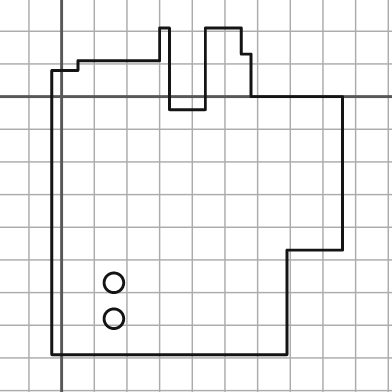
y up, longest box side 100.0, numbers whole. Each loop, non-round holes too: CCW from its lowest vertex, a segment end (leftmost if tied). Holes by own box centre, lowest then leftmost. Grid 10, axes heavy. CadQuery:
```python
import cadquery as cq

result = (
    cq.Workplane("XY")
    .moveTo(-3.0, -79.0)
    .lineTo(69.0, -79.0)
    .lineTo(69.0, -47.0)
    .lineTo(86.0, -47.0)
    .lineTo(86.0, 0.0)
    .lineTo(58.0, 0.0)
    .lineTo(58.0, 13.0)
    .lineTo(55.0, 13.0)
    .lineTo(55.0, 21.0)
    .lineTo(44.0, 21.0)
    .lineTo(44.0, -4.0)
    .lineTo(33.0, -4.0)
    .lineTo(33.0, 21.0)
    .lineTo(30.0, 21.0)
    .lineTo(30.0, 11.0)
    .lineTo(5.0, 11.0)
    .lineTo(5.0, 8.0)
    .lineTo(-3.0, 8.0)
    .close()
    .moveTo(16.0, -68.0)
    .circle(3.0)
    .moveTo(16.0, -57.0)
    .circle(3.0)
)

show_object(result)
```